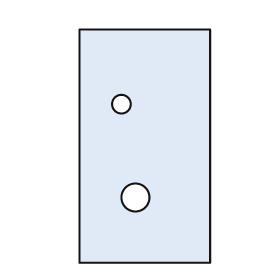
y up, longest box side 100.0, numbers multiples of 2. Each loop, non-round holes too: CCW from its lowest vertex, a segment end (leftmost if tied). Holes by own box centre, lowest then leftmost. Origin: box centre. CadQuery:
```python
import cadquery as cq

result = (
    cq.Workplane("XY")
    .moveTo(-28.0, -50.0)
    .lineTo(28.0, -50.0)
    .lineTo(28.0, 50.0)
    .lineTo(-28.0, 50.0)
    .close()
    .moveTo(-4.0, -22.0)
    .circle(6.0)
    .moveTo(-10.0, 18.0)
    .circle(4.0)
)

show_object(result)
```